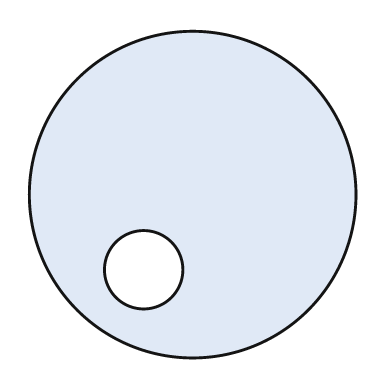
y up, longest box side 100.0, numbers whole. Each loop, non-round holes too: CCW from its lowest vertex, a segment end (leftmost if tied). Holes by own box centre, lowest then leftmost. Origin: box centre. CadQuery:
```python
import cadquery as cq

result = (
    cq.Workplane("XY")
    .moveTo(0.0, 0.0)
    .circle(50.0)
    .moveTo(-15.0, -23.0)
    .circle(12.0)
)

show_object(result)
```